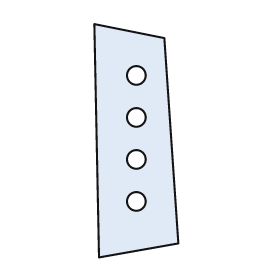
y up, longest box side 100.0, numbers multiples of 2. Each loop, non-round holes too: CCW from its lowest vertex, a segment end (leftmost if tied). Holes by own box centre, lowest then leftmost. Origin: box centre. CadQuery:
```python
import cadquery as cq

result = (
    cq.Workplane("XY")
    .moveTo(-16.0, -50.0)
    .lineTo(18.0, -44.0)
    .lineTo(12.0, 44.0)
    .lineTo(-18.0, 50.0)
    .close()
    .moveTo(0.0, -26.0)
    .circle(4.0)
    .moveTo(0.0, -8.0)
    .circle(4.0)
    .moveTo(0.0, 10.0)
    .circle(4.0)
    .moveTo(0.0, 28.0)
    .circle(4.0)
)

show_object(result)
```